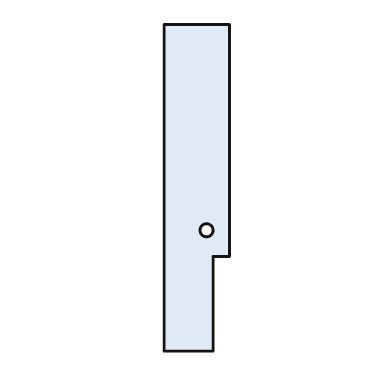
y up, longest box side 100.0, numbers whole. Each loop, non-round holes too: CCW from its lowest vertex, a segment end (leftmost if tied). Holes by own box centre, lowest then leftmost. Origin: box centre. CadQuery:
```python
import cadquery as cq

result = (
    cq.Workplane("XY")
    .moveTo(-10.0, -50.0)
    .lineTo(5.0, -50.0)
    .lineTo(5.0, -21.0)
    .lineTo(10.0, -21.0)
    .lineTo(10.0, 50.0)
    .lineTo(-10.0, 50.0)
    .close()
    .moveTo(3.0, -13.0)
    .circle(2.0)
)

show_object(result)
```